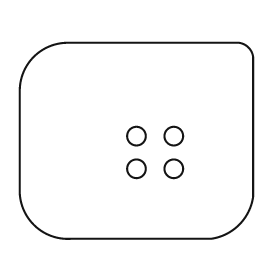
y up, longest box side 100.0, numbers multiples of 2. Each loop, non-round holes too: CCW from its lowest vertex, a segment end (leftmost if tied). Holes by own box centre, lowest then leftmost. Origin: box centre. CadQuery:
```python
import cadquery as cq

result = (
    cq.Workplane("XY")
    .moveTo(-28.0, -42.0)
    .lineTo(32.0, -42.0)
    .threePointArc((44.0, -36.0), (50.0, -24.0))
    .lineTo(50.0, 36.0)
    .threePointArc((48.0, 40.0), (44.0, 42.0))
    .lineTo(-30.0, 42.0)
    .threePointArc((-44.0, 36.0), (-50.0, 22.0))
    .lineTo(-50.0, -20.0)
    .threePointArc((-44.0, -36.0), (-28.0, -42.0))
    .close()
    .moveTo(0.0, -12.0)
    .circle(4.0)
    .moveTo(16.0, -12.0)
    .circle(4.0)
    .moveTo(0.0, 2.0)
    .circle(4.0)
    .moveTo(16.0, 2.0)
    .circle(4.0)
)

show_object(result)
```